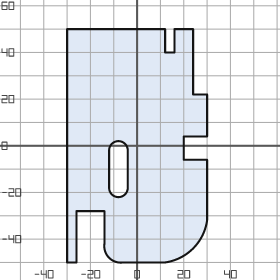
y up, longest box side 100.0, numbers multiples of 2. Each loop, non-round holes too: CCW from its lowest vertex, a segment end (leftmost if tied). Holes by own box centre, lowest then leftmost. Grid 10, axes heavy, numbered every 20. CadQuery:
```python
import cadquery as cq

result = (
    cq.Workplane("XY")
    .moveTo(-30.0, -50.0)
    .lineTo(-26.0, -50.0)
    .lineTo(-26.0, -28.0)
    .lineTo(-14.0, -28.0)
    .lineTo(-14.0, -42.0)
    .threePointArc((-12.0, -48.0), (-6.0, -50.0))
    .lineTo(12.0, -50.0)
    .threePointArc((24.0, -44.0), (30.0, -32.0))
    .lineTo(30.0, -6.0)
    .lineTo(20.0, -6.0)
    .lineTo(20.0, 4.0)
    .lineTo(30.0, 4.0)
    .lineTo(30.0, 22.0)
    .lineTo(24.0, 22.0)
    .lineTo(24.0, 50.0)
    .lineTo(16.0, 50.0)
    .lineTo(16.0, 40.0)
    .lineTo(12.0, 40.0)
    .lineTo(12.0, 50.0)
    .lineTo(-30.0, 50.0)
    .close()
    .moveTo(-12.0, -18.0)
    .threePointArc((-8.0, -22.0), (-4.0, -18.0))
    .lineTo(-4.0, -2.0)
    .threePointArc((-8.0, 2.0), (-12.0, -2.0))
    .close()
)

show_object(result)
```